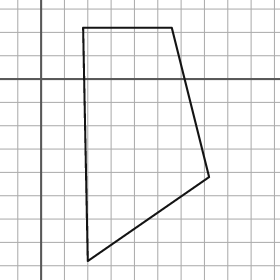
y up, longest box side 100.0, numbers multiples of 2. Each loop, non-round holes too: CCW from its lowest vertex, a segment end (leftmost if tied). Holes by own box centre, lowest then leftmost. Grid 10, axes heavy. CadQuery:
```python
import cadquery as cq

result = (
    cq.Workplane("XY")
    .moveTo(20.0, -78.0)
    .lineTo(72.0, -42.0)
    .lineTo(56.0, 22.0)
    .lineTo(18.0, 22.0)
    .close()
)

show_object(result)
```